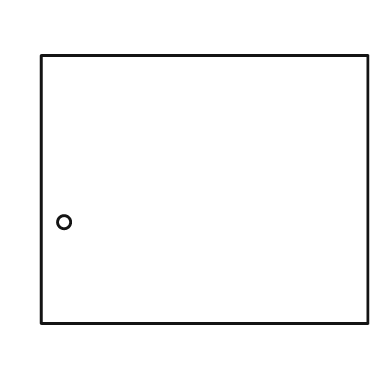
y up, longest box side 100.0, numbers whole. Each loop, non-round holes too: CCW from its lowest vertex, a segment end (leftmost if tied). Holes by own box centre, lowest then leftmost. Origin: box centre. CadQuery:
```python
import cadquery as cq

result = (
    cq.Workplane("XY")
    .moveTo(-50.0, -41.0)
    .lineTo(50.0, -41.0)
    .lineTo(50.0, 41.0)
    .lineTo(-50.0, 41.0)
    .close()
    .moveTo(-43.0, -10.0)
    .circle(2.0)
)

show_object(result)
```